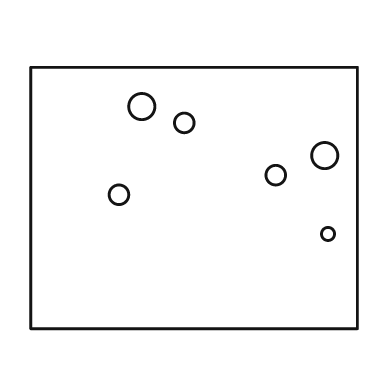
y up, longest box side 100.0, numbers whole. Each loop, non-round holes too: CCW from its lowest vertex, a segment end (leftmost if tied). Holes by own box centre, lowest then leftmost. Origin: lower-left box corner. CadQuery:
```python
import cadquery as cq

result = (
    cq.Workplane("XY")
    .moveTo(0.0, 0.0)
    .lineTo(100.0, 0.0)
    .lineTo(100.0, 80.0)
    .lineTo(0.0, 80.0)
    .close()
    .moveTo(91.0, 29.0)
    .circle(2.0)
    .moveTo(27.0, 41.0)
    .circle(3.0)
    .moveTo(75.0, 47.0)
    .circle(3.0)
    .moveTo(90.0, 53.0)
    .circle(4.0)
    .moveTo(47.0, 63.0)
    .circle(3.0)
    .moveTo(34.0, 68.0)
    .circle(4.0)
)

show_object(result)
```